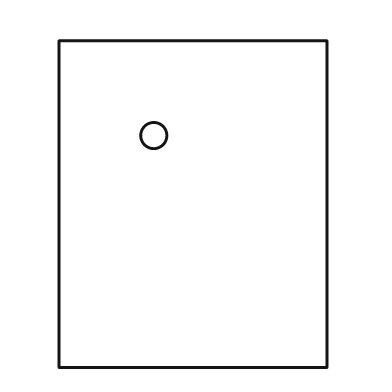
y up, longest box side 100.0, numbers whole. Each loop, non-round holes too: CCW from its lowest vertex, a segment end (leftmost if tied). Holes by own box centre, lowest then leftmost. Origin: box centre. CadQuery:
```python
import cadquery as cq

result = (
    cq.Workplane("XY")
    .moveTo(-41.0, -50.0)
    .lineTo(41.0, -50.0)
    .lineTo(41.0, 50.0)
    .lineTo(-41.0, 50.0)
    .close()
    .moveTo(-12.0, 21.0)
    .circle(4.0)
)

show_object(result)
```